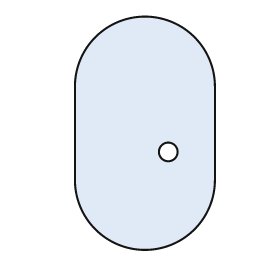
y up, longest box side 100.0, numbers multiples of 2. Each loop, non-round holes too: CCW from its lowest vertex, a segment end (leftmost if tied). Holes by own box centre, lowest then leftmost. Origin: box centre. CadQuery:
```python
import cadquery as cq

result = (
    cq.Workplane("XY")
    .moveTo(-30.0, -20.0)
    .threePointArc((0.0, -50.0), (30.0, -20.0))
    .lineTo(30.0, 20.0)
    .threePointArc((0.0, 50.0), (-30.0, 20.0))
    .close()
    .moveTo(10.0, -8.0)
    .circle(4.0)
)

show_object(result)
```